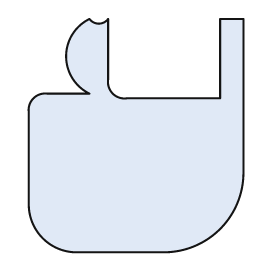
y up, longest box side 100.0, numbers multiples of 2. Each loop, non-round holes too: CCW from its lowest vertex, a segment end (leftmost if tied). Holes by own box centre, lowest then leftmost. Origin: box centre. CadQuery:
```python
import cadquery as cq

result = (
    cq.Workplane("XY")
    .moveTo(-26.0, -50.0)
    .lineTo(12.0, -50.0)
    .threePointArc((36.0, -40.0), (46.0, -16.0))
    .lineTo(46.0, 50.0)
    .lineTo(36.0, 50.0)
    .lineTo(36.0, 16.0)
    .lineTo(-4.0, 16.0)
    .threePointArc((-10.0, 18.0), (-12.0, 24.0))
    .lineTo(-12.0, 50.0)
    .threePointArc((-16.0, 48.0), (-20.0, 50.0))
    .threePointArc((-30.0, 34.0), (-20.0, 18.0))
    .lineTo(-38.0, 18.0)
    .threePointArc((-44.0, 16.0), (-46.0, 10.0))
    .lineTo(-46.0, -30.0)
    .threePointArc((-40.0, -44.0), (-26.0, -50.0))
    .close()
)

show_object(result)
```